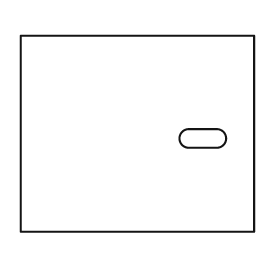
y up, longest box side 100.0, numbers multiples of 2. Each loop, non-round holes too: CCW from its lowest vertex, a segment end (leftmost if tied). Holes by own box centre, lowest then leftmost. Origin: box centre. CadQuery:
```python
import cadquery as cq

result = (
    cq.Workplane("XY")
    .moveTo(-50.0, -42.0)
    .lineTo(50.0, -42.0)
    .lineTo(50.0, 42.0)
    .lineTo(-50.0, 42.0)
    .close()
    .moveTo(22.0, -6.0)
    .lineTo(34.0, -6.0)
    .threePointArc((38.0, -2.0), (34.0, 2.0))
    .lineTo(22.0, 2.0)
    .threePointArc((18.0, -2.0), (22.0, -6.0))
    .close()
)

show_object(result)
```